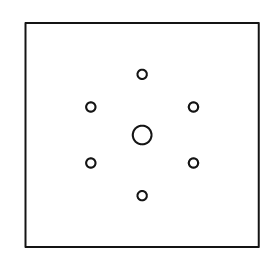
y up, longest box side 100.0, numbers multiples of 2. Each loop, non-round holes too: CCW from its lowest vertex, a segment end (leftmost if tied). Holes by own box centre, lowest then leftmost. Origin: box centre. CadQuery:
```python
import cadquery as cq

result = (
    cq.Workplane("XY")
    .moveTo(-50.0, -48.0)
    .lineTo(50.0, -48.0)
    .lineTo(50.0, 48.0)
    .lineTo(-50.0, 48.0)
    .close()
    .moveTo(0.0, -26.0)
    .circle(2.0)
    .moveTo(-22.0, -12.0)
    .circle(2.0)
    .moveTo(22.0, -12.0)
    .circle(2.0)
    .moveTo(0.0, 0.0)
    .circle(4.0)
    .moveTo(-22.0, 12.0)
    .circle(2.0)
    .moveTo(22.0, 12.0)
    .circle(2.0)
    .moveTo(0.0, 26.0)
    .circle(2.0)
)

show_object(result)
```